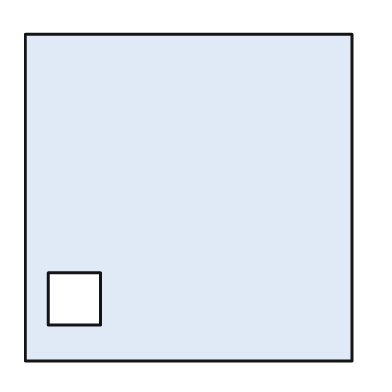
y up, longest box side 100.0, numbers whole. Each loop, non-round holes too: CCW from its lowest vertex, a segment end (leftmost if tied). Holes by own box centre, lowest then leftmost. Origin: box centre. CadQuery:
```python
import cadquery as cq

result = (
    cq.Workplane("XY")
    .moveTo(-50.0, -50.0)
    .lineTo(50.0, -50.0)
    .lineTo(50.0, 50.0)
    .lineTo(-50.0, 50.0)
    .close()
    .moveTo(-43.0, -39.0)
    .lineTo(-27.0, -39.0)
    .lineTo(-27.0, -23.0)
    .lineTo(-43.0, -23.0)
    .close()
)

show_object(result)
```